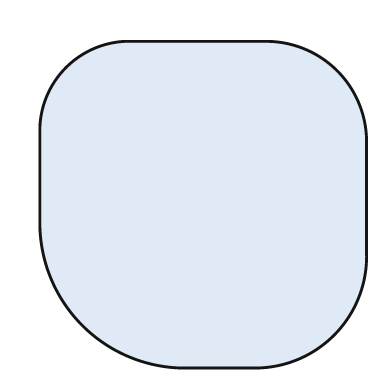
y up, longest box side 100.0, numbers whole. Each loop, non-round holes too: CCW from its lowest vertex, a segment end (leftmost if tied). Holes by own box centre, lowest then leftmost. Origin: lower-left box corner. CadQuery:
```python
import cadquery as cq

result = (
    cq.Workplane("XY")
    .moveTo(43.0, 0.0)
    .lineTo(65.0, 0.0)
    .threePointArc((90.0, 10.0), (100.0, 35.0))
    .lineTo(100.0, 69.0)
    .threePointArc((91.0, 91.0), (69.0, 100.0))
    .lineTo(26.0, 100.0)
    .threePointArc((8.0, 92.0), (0.0, 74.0))
    .lineTo(0.0, 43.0)
    .threePointArc((13.0, 13.0), (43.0, 0.0))
    .close()
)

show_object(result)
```